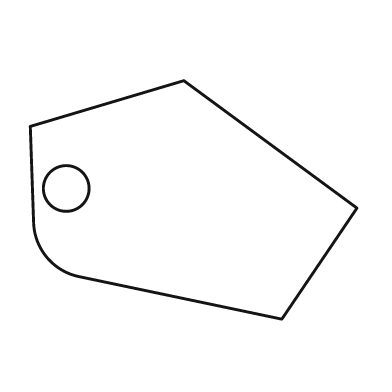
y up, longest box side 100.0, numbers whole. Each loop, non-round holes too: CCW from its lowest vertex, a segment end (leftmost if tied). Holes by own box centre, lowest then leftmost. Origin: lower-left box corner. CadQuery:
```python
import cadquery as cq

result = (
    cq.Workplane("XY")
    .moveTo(77.0, 0.0)
    .lineTo(100.0, 34.0)
    .lineTo(47.0, 73.0)
    .lineTo(0.0, 59.0)
    .lineTo(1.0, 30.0)
    .threePointArc((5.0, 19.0), (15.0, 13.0))
    .close()
    .moveTo(11.0, 40.0)
    .circle(7.0)
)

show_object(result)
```